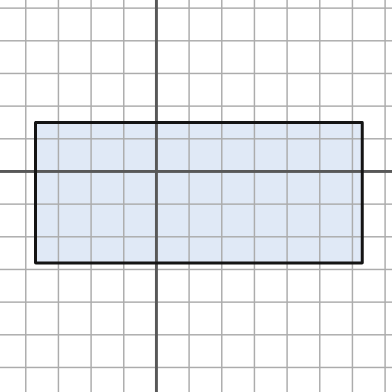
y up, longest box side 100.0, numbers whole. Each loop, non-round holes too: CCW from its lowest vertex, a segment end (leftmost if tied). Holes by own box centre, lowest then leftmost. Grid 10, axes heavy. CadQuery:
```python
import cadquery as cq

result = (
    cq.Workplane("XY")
    .moveTo(-37.0, -28.0)
    .lineTo(63.0, -28.0)
    .lineTo(63.0, 15.0)
    .lineTo(-37.0, 15.0)
    .close()
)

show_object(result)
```